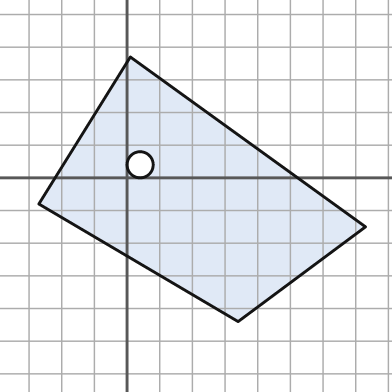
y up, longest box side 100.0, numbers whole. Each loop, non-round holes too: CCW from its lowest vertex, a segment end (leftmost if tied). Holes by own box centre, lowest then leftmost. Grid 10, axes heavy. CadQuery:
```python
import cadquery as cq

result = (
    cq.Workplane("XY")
    .moveTo(34.0, -44.0)
    .lineTo(73.0, -15.0)
    .lineTo(1.0, 37.0)
    .lineTo(-27.0, -8.0)
    .close()
    .moveTo(4.0, 4.0)
    .circle(4.0)
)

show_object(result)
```